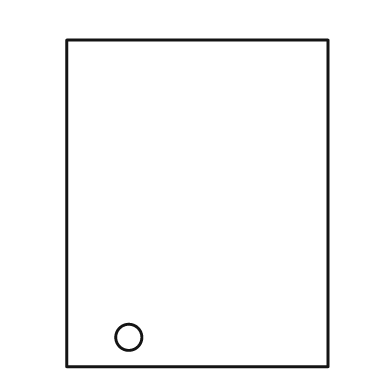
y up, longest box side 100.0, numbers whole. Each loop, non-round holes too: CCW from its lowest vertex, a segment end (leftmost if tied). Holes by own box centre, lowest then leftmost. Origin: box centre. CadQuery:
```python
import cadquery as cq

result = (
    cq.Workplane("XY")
    .moveTo(-40.0, -50.0)
    .lineTo(40.0, -50.0)
    .lineTo(40.0, 50.0)
    .lineTo(-40.0, 50.0)
    .close()
    .moveTo(-21.0, -41.0)
    .circle(4.0)
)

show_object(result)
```